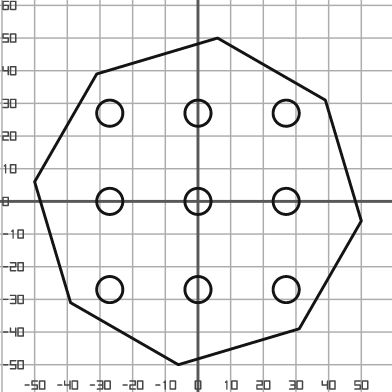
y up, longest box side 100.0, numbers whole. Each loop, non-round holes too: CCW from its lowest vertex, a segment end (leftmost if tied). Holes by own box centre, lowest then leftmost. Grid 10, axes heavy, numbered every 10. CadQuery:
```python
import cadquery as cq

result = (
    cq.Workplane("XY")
    .moveTo(-6.0, -50.0)
    .lineTo(31.0, -39.0)
    .lineTo(50.0, -6.0)
    .lineTo(39.0, 31.0)
    .lineTo(6.0, 50.0)
    .lineTo(-31.0, 39.0)
    .lineTo(-50.0, 6.0)
    .lineTo(-39.0, -31.0)
    .close()
    .moveTo(-27.0, -27.0)
    .circle(4.0)
    .moveTo(0.0, -27.0)
    .circle(4.0)
    .moveTo(27.0, -27.0)
    .circle(4.0)
    .moveTo(-27.0, 0.0)
    .circle(4.0)
    .moveTo(0.0, 0.0)
    .circle(4.0)
    .moveTo(27.0, 0.0)
    .circle(4.0)
    .moveTo(-27.0, 27.0)
    .circle(4.0)
    .moveTo(0.0, 27.0)
    .circle(4.0)
    .moveTo(27.0, 27.0)
    .circle(4.0)
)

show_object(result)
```